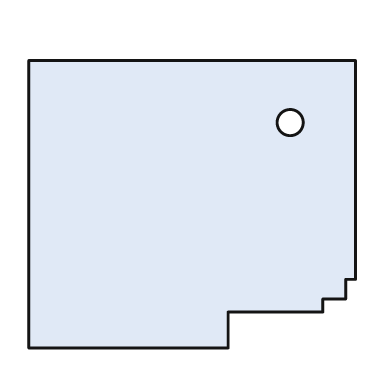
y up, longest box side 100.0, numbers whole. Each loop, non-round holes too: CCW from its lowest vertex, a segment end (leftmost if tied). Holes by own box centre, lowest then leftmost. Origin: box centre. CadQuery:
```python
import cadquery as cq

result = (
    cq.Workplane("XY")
    .moveTo(-50.0, -44.0)
    .lineTo(11.0, -44.0)
    .lineTo(11.0, -33.0)
    .lineTo(40.0, -33.0)
    .lineTo(40.0, -29.0)
    .lineTo(47.0, -29.0)
    .lineTo(47.0, -23.0)
    .lineTo(50.0, -23.0)
    .lineTo(50.0, 44.0)
    .lineTo(-50.0, 44.0)
    .close()
    .moveTo(30.0, 25.0)
    .circle(4.0)
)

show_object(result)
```